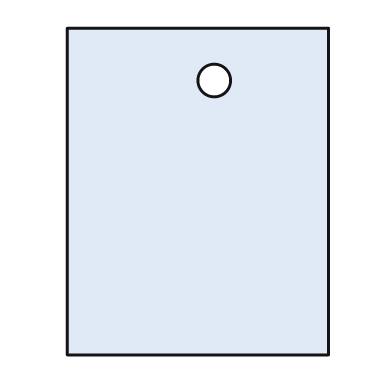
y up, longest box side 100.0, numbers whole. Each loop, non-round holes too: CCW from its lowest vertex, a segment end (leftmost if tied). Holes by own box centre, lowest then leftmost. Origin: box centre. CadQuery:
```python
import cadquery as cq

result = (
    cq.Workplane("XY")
    .moveTo(-40.0, -50.0)
    .lineTo(40.0, -50.0)
    .lineTo(40.0, 50.0)
    .lineTo(-40.0, 50.0)
    .close()
    .moveTo(5.0, 34.0)
    .circle(5.0)
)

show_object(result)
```